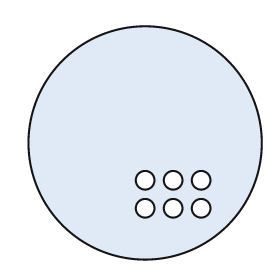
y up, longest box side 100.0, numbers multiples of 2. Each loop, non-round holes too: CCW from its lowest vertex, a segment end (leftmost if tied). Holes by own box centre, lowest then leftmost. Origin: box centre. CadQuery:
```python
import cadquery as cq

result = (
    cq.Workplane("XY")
    .moveTo(0.0, 0.0)
    .circle(50.0)
    .moveTo(0.0, -28.0)
    .circle(4.0)
    .moveTo(12.0, -28.0)
    .circle(4.0)
    .moveTo(24.0, -28.0)
    .circle(4.0)
    .moveTo(0.0, -16.0)
    .circle(4.0)
    .moveTo(12.0, -16.0)
    .circle(4.0)
    .moveTo(24.0, -16.0)
    .circle(4.0)
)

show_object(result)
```